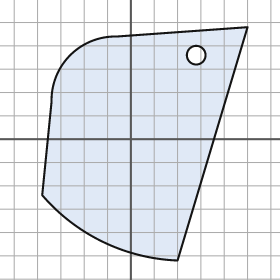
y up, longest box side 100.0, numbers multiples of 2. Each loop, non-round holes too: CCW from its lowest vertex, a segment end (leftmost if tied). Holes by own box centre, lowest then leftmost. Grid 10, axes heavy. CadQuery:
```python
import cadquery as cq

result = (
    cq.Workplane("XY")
    .moveTo(20.0, -52.0)
    .lineTo(50.0, 48.0)
    .lineTo(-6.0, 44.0)
    .threePointArc((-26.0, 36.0), (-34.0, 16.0))
    .lineTo(-38.0, -24.0)
    .threePointArc((-12.0, -44.0), (20.0, -52.0))
    .close()
    .moveTo(28.0, 36.0)
    .circle(4.0)
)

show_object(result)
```